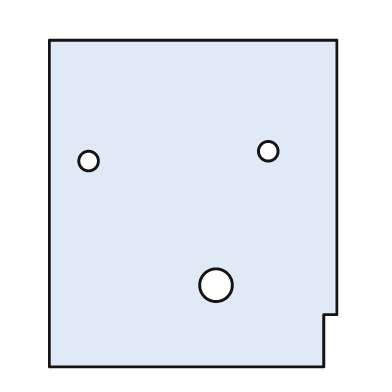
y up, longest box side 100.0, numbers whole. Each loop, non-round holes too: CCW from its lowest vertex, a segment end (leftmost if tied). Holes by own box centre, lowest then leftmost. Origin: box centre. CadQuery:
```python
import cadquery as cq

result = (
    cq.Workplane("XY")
    .moveTo(-44.0, -50.0)
    .lineTo(40.0, -50.0)
    .lineTo(40.0, -34.0)
    .lineTo(44.0, -34.0)
    .lineTo(44.0, 50.0)
    .lineTo(-44.0, 50.0)
    .close()
    .moveTo(7.0, -25.0)
    .circle(5.0)
    .moveTo(-32.0, 13.0)
    .circle(3.0)
    .moveTo(23.0, 16.0)
    .circle(3.0)
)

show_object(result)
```